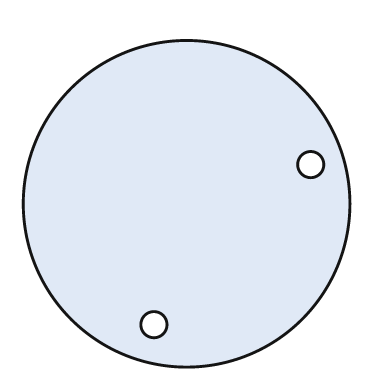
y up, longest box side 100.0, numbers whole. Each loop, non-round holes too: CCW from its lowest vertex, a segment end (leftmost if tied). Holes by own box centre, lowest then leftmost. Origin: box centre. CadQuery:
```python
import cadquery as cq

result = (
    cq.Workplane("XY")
    .moveTo(0.0, 0.0)
    .circle(50.0)
    .moveTo(-10.0, -37.0)
    .circle(4.0)
    .moveTo(38.0, 12.0)
    .circle(4.0)
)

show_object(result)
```